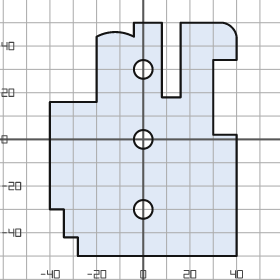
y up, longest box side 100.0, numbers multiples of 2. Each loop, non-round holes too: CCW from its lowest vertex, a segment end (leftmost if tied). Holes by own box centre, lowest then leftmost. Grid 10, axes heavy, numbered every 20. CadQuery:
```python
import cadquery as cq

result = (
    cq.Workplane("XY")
    .moveTo(-28.0, -50.0)
    .lineTo(40.0, -50.0)
    .lineTo(40.0, 2.0)
    .lineTo(30.0, 2.0)
    .lineTo(30.0, 34.0)
    .lineTo(40.0, 34.0)
    .lineTo(40.0, 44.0)
    .threePointArc((38.0, 48.0), (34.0, 50.0))
    .lineTo(16.0, 50.0)
    .lineTo(16.0, 18.0)
    .lineTo(8.0, 18.0)
    .lineTo(8.0, 50.0)
    .lineTo(-4.0, 50.0)
    .lineTo(-4.0, 44.0)
    .threePointArc((-12.0, 46.0), (-20.0, 44.0))
    .lineTo(-20.0, 16.0)
    .lineTo(-40.0, 16.0)
    .lineTo(-40.0, -30.0)
    .lineTo(-34.0, -30.0)
    .lineTo(-34.0, -42.0)
    .lineTo(-28.0, -42.0)
    .close()
    .moveTo(0.0, -30.0)
    .circle(4.0)
    .moveTo(0.0, 0.0)
    .circle(4.0)
    .moveTo(0.0, 30.0)
    .circle(4.0)
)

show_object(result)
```